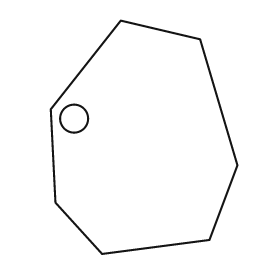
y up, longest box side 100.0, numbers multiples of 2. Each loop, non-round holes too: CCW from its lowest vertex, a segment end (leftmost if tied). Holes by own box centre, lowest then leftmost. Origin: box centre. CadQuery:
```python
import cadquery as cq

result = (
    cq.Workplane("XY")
    .moveTo(-18.0, -50.0)
    .lineTo(28.0, -44.0)
    .lineTo(40.0, -12.0)
    .lineTo(24.0, 42.0)
    .lineTo(-10.0, 50.0)
    .lineTo(-40.0, 12.0)
    .lineTo(-38.0, -28.0)
    .close()
    .moveTo(-30.0, 8.0)
    .circle(6.0)
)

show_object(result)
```